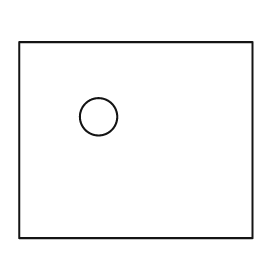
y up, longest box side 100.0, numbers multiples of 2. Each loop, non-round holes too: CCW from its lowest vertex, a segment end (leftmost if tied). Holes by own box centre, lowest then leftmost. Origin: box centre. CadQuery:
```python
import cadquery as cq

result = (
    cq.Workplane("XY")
    .moveTo(-50.0, -42.0)
    .lineTo(50.0, -42.0)
    .lineTo(50.0, 42.0)
    .lineTo(-50.0, 42.0)
    .close()
    .moveTo(-16.0, 10.0)
    .circle(8.0)
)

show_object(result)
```